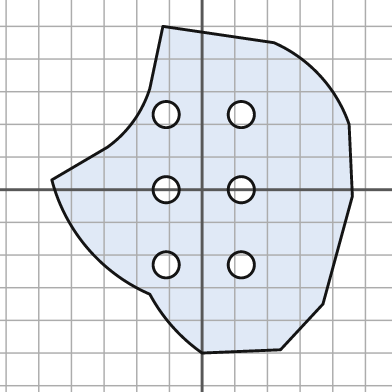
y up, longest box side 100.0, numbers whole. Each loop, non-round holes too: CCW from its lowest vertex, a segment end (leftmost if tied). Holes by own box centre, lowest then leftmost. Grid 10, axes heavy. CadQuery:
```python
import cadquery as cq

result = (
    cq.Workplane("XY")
    .moveTo(0.0, -50.0)
    .lineTo(24.0, -49.0)
    .lineTo(37.0, -35.0)
    .lineTo(46.0, -2.0)
    .lineTo(45.0, 20.0)
    .threePointArc((36.0, 35.0), (22.0, 45.0))
    .lineTo(-12.0, 50.0)
    .lineTo(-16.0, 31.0)
    .threePointArc((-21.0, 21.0), (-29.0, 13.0))
    .lineTo(-46.0, 3.0)
    .threePointArc((-35.0, -18.0), (-16.0, -32.0))
    .threePointArc((-9.0, -42.0), (0.0, -50.0))
    .close()
    .moveTo(-11.0, -23.0)
    .circle(4.0)
    .moveTo(12.0, -23.0)
    .circle(4.0)
    .moveTo(-11.0, 0.0)
    .circle(4.0)
    .moveTo(12.0, 0.0)
    .circle(4.0)
    .moveTo(-11.0, 23.0)
    .circle(4.0)
    .moveTo(12.0, 23.0)
    .circle(4.0)
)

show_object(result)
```